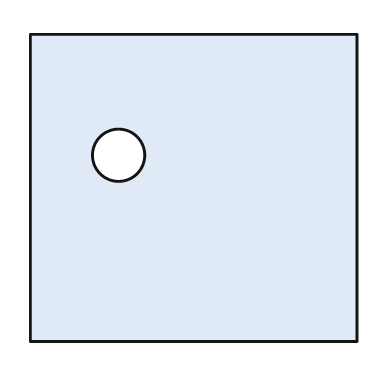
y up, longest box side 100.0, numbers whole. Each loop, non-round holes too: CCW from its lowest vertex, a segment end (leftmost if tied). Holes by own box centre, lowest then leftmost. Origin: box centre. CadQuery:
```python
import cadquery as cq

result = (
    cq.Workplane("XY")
    .moveTo(-50.0, -47.0)
    .lineTo(50.0, -47.0)
    .lineTo(50.0, 47.0)
    .lineTo(-50.0, 47.0)
    .close()
    .moveTo(-23.0, 10.0)
    .circle(8.0)
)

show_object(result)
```